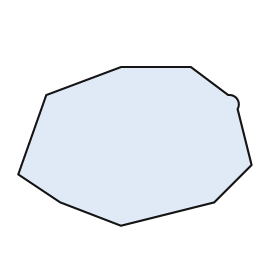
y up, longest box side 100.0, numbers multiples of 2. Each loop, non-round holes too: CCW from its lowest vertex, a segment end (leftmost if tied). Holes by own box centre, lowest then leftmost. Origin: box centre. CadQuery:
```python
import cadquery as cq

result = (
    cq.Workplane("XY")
    .moveTo(-6.0, -34.0)
    .lineTo(34.0, -24.0)
    .lineTo(50.0, -8.0)
    .lineTo(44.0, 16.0)
    .threePointArc((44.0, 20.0), (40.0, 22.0))
    .lineTo(24.0, 34.0)
    .lineTo(-6.0, 34.0)
    .lineTo(-38.0, 22.0)
    .lineTo(-50.0, -12.0)
    .lineTo(-32.0, -24.0)
    .close()
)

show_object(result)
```